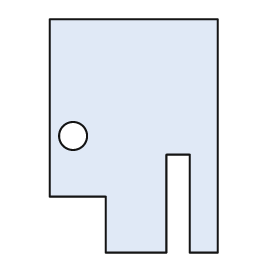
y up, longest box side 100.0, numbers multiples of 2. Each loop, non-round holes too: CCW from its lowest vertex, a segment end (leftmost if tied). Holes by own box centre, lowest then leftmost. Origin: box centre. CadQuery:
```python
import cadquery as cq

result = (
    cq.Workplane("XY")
    .moveTo(-12.0, -50.0)
    .lineTo(14.0, -50.0)
    .lineTo(14.0, -8.0)
    .lineTo(24.0, -8.0)
    .lineTo(24.0, -50.0)
    .lineTo(36.0, -50.0)
    .lineTo(36.0, 50.0)
    .lineTo(-36.0, 50.0)
    .lineTo(-36.0, -26.0)
    .lineTo(-12.0, -26.0)
    .close()
    .moveTo(-26.0, 0.0)
    .circle(6.0)
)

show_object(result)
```